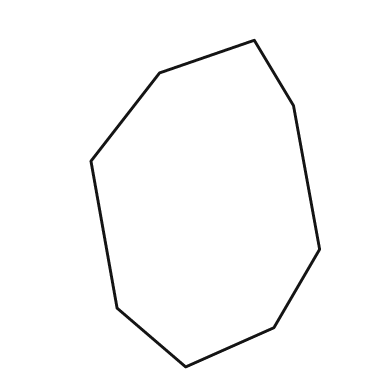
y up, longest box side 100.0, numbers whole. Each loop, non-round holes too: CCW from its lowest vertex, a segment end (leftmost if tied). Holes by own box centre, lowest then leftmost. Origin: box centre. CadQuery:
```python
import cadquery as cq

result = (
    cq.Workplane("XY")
    .moveTo(-6.0, -50.0)
    .lineTo(21.0, -38.0)
    .lineTo(35.0, -14.0)
    .lineTo(27.0, 30.0)
    .lineTo(15.0, 50.0)
    .lineTo(-14.0, 40.0)
    .lineTo(-35.0, 13.0)
    .lineTo(-27.0, -32.0)
    .close()
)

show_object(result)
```